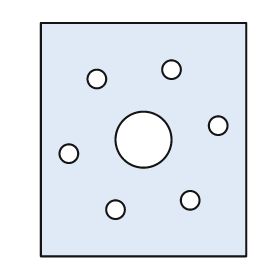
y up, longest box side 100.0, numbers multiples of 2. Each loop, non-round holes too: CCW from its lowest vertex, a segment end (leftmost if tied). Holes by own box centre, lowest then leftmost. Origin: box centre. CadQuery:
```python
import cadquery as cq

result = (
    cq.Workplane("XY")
    .moveTo(-44.0, -50.0)
    .lineTo(44.0, -50.0)
    .lineTo(44.0, 50.0)
    .lineTo(-44.0, 50.0)
    .close()
    .moveTo(-12.0, -30.0)
    .circle(4.0)
    .moveTo(20.0, -26.0)
    .circle(4.0)
    .moveTo(-32.0, -6.0)
    .circle(4.0)
    .moveTo(0.0, 0.0)
    .circle(12.0)
    .moveTo(32.0, 6.0)
    .circle(4.0)
    .moveTo(-20.0, 26.0)
    .circle(4.0)
    .moveTo(12.0, 30.0)
    .circle(4.0)
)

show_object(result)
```